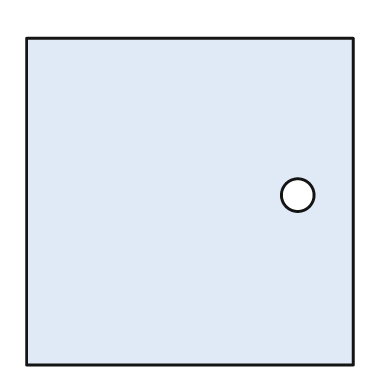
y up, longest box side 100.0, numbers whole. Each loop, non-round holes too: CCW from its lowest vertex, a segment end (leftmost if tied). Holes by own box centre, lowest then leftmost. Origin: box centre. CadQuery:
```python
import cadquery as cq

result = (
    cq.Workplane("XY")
    .moveTo(-50.0, -50.0)
    .lineTo(50.0, -50.0)
    .lineTo(50.0, 50.0)
    .lineTo(-50.0, 50.0)
    .close()
    .moveTo(33.0, 2.0)
    .circle(5.0)
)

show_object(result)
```